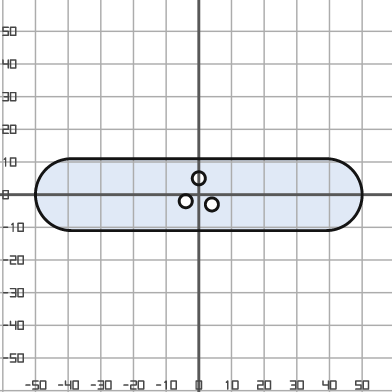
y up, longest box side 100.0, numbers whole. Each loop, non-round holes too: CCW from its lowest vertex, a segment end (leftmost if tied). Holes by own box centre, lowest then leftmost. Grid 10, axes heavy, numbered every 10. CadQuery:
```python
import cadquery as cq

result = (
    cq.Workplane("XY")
    .moveTo(-39.0, -11.0)
    .lineTo(39.0, -11.0)
    .threePointArc((50.0, 0.0), (39.0, 11.0))
    .lineTo(-39.0, 11.0)
    .threePointArc((-50.0, 0.0), (-39.0, -11.0))
    .close()
    .moveTo(4.0, -3.0)
    .circle(2.0)
    .moveTo(-4.0, -2.0)
    .circle(2.0)
    .moveTo(0.0, 5.0)
    .circle(2.0)
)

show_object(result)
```